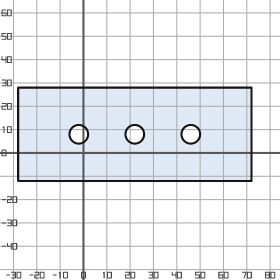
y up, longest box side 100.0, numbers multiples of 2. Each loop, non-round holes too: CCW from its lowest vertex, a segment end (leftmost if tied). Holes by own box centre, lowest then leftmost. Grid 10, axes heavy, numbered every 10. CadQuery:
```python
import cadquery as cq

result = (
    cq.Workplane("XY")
    .moveTo(-28.0, -12.0)
    .lineTo(72.0, -12.0)
    .lineTo(72.0, 28.0)
    .lineTo(-28.0, 28.0)
    .close()
    .moveTo(-2.0, 8.0)
    .circle(4.0)
    .moveTo(22.0, 8.0)
    .circle(4.0)
    .moveTo(46.0, 8.0)
    .circle(4.0)
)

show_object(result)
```